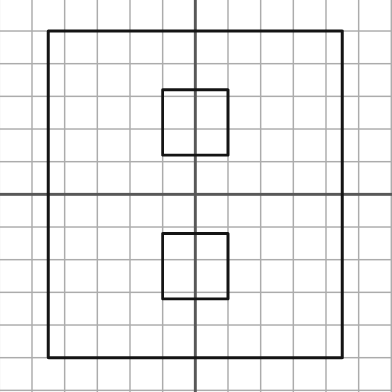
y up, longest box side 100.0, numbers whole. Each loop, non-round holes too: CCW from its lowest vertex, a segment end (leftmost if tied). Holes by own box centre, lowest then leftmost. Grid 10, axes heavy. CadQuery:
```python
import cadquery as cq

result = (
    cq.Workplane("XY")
    .moveTo(-45.0, -50.0)
    .lineTo(45.0, -50.0)
    .lineTo(45.0, 50.0)
    .lineTo(-45.0, 50.0)
    .close()
    .moveTo(-10.0, -32.0)
    .lineTo(10.0, -32.0)
    .lineTo(10.0, -12.0)
    .lineTo(-10.0, -12.0)
    .close()
    .moveTo(-10.0, 12.0)
    .lineTo(10.0, 12.0)
    .lineTo(10.0, 32.0)
    .lineTo(-10.0, 32.0)
    .close()
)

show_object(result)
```